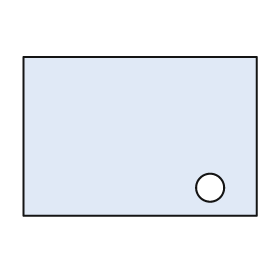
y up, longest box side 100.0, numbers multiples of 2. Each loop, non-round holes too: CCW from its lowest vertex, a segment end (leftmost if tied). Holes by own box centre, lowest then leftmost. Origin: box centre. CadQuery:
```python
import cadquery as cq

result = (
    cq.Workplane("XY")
    .moveTo(-50.0, -34.0)
    .lineTo(50.0, -34.0)
    .lineTo(50.0, 34.0)
    .lineTo(-50.0, 34.0)
    .close()
    .moveTo(30.0, -22.0)
    .circle(6.0)
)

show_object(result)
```